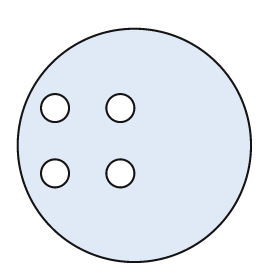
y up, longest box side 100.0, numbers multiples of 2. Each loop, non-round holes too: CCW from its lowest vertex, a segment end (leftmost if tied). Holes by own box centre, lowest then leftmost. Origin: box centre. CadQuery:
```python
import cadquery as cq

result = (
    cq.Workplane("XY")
    .moveTo(0.0, 0.0)
    .circle(50.0)
    .moveTo(-34.0, -12.0)
    .circle(6.0)
    .moveTo(-6.0, -12.0)
    .circle(6.0)
    .moveTo(-34.0, 16.0)
    .circle(6.0)
    .moveTo(-6.0, 16.0)
    .circle(6.0)
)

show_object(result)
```